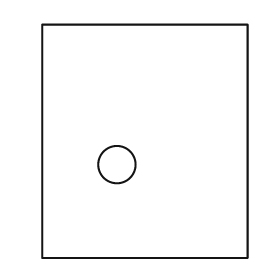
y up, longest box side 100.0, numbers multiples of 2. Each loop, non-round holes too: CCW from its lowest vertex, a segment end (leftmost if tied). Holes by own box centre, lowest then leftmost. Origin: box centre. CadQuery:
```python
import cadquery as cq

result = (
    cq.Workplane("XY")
    .moveTo(-44.0, -50.0)
    .lineTo(44.0, -50.0)
    .lineTo(44.0, 50.0)
    .lineTo(-44.0, 50.0)
    .close()
    .moveTo(-12.0, -10.0)
    .circle(8.0)
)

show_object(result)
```